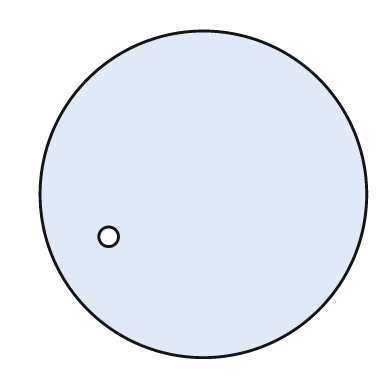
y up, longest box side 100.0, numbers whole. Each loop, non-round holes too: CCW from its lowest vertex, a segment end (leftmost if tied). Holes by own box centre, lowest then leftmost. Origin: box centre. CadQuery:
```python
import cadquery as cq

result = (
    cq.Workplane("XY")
    .moveTo(0.0, 0.0)
    .circle(50.0)
    .moveTo(-29.0, -13.0)
    .circle(3.0)
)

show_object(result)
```